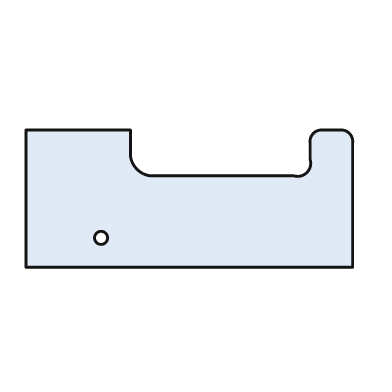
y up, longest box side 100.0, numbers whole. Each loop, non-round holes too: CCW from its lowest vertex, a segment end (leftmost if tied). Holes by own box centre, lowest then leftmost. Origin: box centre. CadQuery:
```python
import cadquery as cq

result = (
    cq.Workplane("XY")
    .moveTo(-50.0, -21.0)
    .lineTo(50.0, -21.0)
    .lineTo(50.0, 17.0)
    .threePointArc((49.0, 20.0), (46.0, 21.0))
    .lineTo(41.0, 21.0)
    .threePointArc((38.0, 20.0), (37.0, 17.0))
    .lineTo(37.0, 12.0)
    .threePointArc((36.0, 8.0), (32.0, 7.0))
    .lineTo(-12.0, 7.0)
    .threePointArc((-16.0, 9.0), (-18.0, 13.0))
    .lineTo(-18.0, 21.0)
    .lineTo(-50.0, 21.0)
    .close()
    .moveTo(-27.0, -12.0)
    .circle(2.0)
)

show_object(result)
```